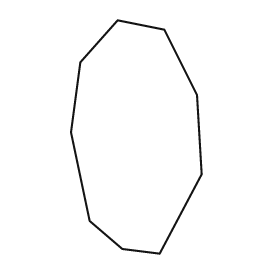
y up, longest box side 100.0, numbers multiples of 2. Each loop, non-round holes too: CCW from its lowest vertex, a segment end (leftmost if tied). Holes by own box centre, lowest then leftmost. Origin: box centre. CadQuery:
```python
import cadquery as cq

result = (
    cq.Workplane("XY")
    .moveTo(10.0, -50.0)
    .lineTo(28.0, -16.0)
    .lineTo(26.0, 18.0)
    .lineTo(12.0, 46.0)
    .lineTo(-8.0, 50.0)
    .lineTo(-24.0, 32.0)
    .lineTo(-28.0, 2.0)
    .lineTo(-20.0, -36.0)
    .lineTo(-6.0, -48.0)
    .close()
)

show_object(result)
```